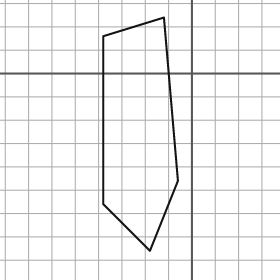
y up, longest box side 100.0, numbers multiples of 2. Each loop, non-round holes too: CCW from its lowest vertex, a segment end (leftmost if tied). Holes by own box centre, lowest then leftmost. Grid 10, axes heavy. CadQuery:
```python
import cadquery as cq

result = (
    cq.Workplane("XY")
    .moveTo(-18.0, -76.0)
    .lineTo(-6.0, -46.0)
    .lineTo(-12.0, 24.0)
    .lineTo(-38.0, 16.0)
    .lineTo(-38.0, -56.0)
    .close()
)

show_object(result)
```